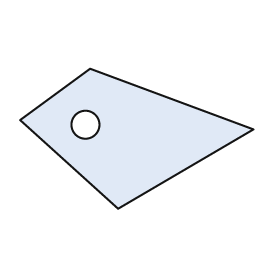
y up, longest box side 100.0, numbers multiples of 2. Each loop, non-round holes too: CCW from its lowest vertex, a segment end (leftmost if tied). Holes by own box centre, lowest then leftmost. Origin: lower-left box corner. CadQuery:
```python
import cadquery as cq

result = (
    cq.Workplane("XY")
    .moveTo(42.0, 0.0)
    .lineTo(100.0, 34.0)
    .lineTo(30.0, 60.0)
    .lineTo(0.0, 38.0)
    .close()
    .moveTo(28.0, 36.0)
    .circle(6.0)
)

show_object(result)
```